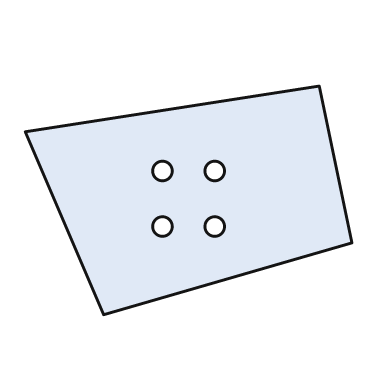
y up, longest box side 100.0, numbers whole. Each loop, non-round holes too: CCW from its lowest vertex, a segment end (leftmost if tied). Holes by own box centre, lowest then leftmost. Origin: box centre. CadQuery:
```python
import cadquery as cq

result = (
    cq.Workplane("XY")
    .moveTo(-26.0, -35.0)
    .lineTo(50.0, -13.0)
    .lineTo(40.0, 35.0)
    .lineTo(-50.0, 21.0)
    .close()
    .moveTo(-8.0, -8.0)
    .circle(3.0)
    .moveTo(8.0, -8.0)
    .circle(3.0)
    .moveTo(-8.0, 9.0)
    .circle(3.0)
    .moveTo(8.0, 9.0)
    .circle(3.0)
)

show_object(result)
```